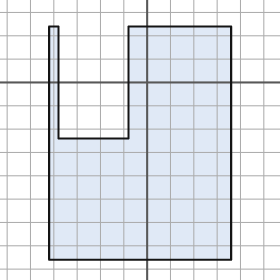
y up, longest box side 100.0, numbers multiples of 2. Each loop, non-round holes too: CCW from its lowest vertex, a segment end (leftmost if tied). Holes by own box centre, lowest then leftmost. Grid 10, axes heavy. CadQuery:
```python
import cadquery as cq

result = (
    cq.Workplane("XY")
    .moveTo(-42.0, -76.0)
    .lineTo(36.0, -76.0)
    .lineTo(36.0, 24.0)
    .lineTo(-8.0, 24.0)
    .lineTo(-8.0, -24.0)
    .lineTo(-38.0, -24.0)
    .lineTo(-38.0, 24.0)
    .lineTo(-42.0, 24.0)
    .close()
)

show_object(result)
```